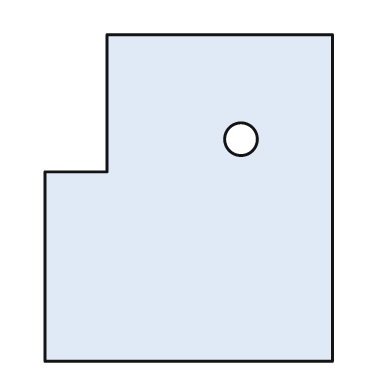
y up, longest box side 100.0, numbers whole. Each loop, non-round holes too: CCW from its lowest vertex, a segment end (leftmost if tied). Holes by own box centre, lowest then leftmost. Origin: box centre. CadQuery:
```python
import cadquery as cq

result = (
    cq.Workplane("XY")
    .moveTo(-44.0, -50.0)
    .lineTo(44.0, -50.0)
    .lineTo(44.0, 50.0)
    .lineTo(-25.0, 50.0)
    .lineTo(-25.0, 8.0)
    .lineTo(-44.0, 8.0)
    .close()
    .moveTo(16.0, 18.0)
    .circle(5.0)
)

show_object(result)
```